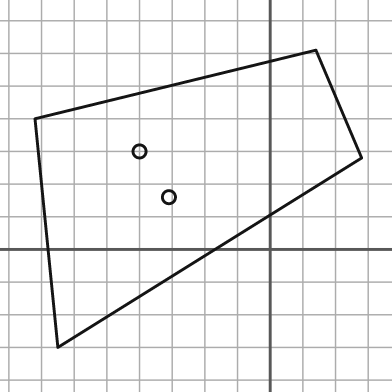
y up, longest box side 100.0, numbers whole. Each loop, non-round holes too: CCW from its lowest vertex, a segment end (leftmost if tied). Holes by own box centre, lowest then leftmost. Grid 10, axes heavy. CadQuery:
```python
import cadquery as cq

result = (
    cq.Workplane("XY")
    .moveTo(-65.0, -30.0)
    .lineTo(28.0, 28.0)
    .lineTo(14.0, 61.0)
    .lineTo(-72.0, 40.0)
    .close()
    .moveTo(-31.0, 16.0)
    .circle(2.0)
    .moveTo(-40.0, 30.0)
    .circle(2.0)
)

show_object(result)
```